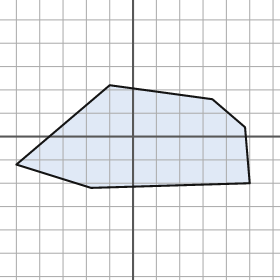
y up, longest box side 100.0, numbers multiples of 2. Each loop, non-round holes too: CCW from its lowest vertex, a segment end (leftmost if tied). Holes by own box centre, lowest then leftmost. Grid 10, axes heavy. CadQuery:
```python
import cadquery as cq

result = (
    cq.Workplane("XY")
    .moveTo(-18.0, -22.0)
    .lineTo(50.0, -20.0)
    .lineTo(48.0, 4.0)
    .lineTo(34.0, 16.0)
    .lineTo(-10.0, 22.0)
    .lineTo(-50.0, -12.0)
    .close()
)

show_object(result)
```